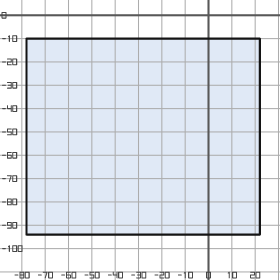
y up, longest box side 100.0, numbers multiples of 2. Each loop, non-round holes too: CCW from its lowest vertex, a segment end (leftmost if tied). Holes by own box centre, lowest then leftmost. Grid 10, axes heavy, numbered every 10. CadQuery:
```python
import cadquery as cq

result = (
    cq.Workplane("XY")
    .moveTo(-78.0, -94.0)
    .lineTo(22.0, -94.0)
    .lineTo(22.0, -10.0)
    .lineTo(-78.0, -10.0)
    .close()
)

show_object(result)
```